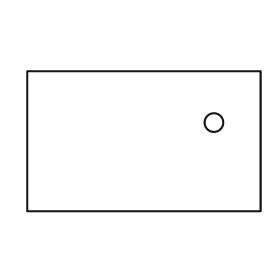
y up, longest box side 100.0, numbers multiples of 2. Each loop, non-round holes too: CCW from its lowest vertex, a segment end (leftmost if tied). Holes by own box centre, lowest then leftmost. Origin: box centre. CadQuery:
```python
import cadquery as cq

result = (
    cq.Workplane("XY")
    .moveTo(-50.0, -30.0)
    .lineTo(50.0, -30.0)
    .lineTo(50.0, 30.0)
    .lineTo(-50.0, 30.0)
    .close()
    .moveTo(30.0, 8.0)
    .circle(4.0)
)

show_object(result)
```